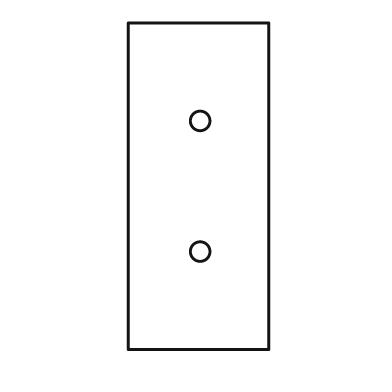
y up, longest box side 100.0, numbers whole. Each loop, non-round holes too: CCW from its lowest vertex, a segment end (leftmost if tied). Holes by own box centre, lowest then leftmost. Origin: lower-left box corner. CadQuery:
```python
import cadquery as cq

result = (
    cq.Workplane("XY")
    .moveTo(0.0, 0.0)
    .lineTo(43.0, 0.0)
    .lineTo(43.0, 100.0)
    .lineTo(0.0, 100.0)
    .close()
    .moveTo(22.0, 30.0)
    .circle(3.0)
    .moveTo(22.0, 70.0)
    .circle(3.0)
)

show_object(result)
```